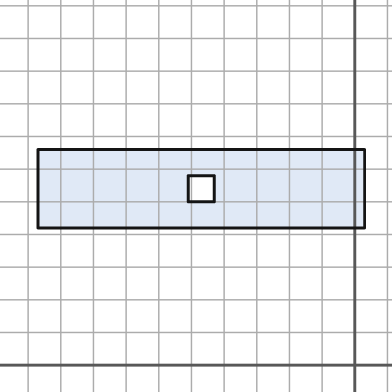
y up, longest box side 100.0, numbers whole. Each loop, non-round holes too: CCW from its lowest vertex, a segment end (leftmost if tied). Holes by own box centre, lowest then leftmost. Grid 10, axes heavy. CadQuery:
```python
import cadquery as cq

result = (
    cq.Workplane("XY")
    .moveTo(-97.0, 42.0)
    .lineTo(3.0, 42.0)
    .lineTo(3.0, 66.0)
    .lineTo(-97.0, 66.0)
    .close()
    .moveTo(-51.0, 50.0)
    .lineTo(-43.0, 50.0)
    .lineTo(-43.0, 58.0)
    .lineTo(-51.0, 58.0)
    .close()
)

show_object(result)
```